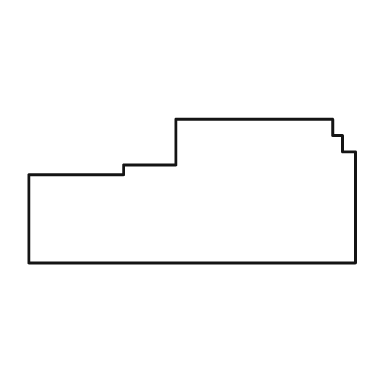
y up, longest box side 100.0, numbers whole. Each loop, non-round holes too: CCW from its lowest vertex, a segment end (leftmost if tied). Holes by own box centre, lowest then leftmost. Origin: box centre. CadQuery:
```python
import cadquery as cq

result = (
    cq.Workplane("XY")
    .moveTo(-50.0, -22.0)
    .lineTo(50.0, -22.0)
    .lineTo(50.0, 12.0)
    .lineTo(46.0, 12.0)
    .lineTo(46.0, 17.0)
    .lineTo(43.0, 17.0)
    .lineTo(43.0, 22.0)
    .lineTo(-5.0, 22.0)
    .lineTo(-5.0, 8.0)
    .lineTo(-21.0, 8.0)
    .lineTo(-21.0, 5.0)
    .lineTo(-50.0, 5.0)
    .close()
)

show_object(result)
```